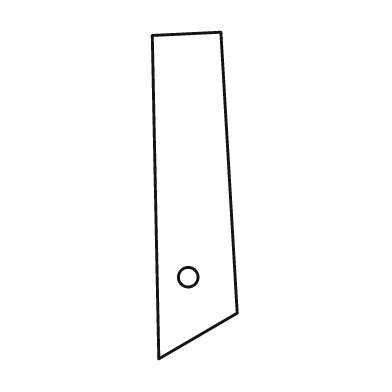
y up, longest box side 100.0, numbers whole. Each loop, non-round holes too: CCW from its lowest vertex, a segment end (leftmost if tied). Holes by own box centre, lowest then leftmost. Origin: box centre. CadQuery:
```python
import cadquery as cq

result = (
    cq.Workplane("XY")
    .moveTo(-11.0, -50.0)
    .lineTo(13.0, -36.0)
    .lineTo(8.0, 50.0)
    .lineTo(-13.0, 49.0)
    .close()
    .moveTo(-2.0, -25.0)
    .circle(3.0)
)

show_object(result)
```